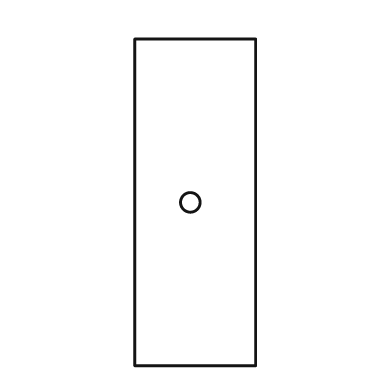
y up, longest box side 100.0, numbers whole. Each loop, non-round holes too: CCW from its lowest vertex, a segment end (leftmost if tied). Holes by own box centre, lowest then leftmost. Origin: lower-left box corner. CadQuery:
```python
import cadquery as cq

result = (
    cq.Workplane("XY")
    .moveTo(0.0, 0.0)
    .lineTo(37.0, 0.0)
    .lineTo(37.0, 100.0)
    .lineTo(0.0, 100.0)
    .close()
    .moveTo(17.0, 50.0)
    .circle(3.0)
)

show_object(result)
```